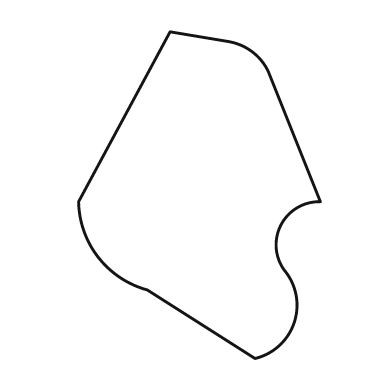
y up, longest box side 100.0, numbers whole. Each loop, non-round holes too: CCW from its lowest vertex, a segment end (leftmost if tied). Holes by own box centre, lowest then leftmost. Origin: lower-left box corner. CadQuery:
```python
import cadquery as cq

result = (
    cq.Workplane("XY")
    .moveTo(54.0, 0.0)
    .threePointArc((66.0, 11.0), (63.0, 27.0))
    .threePointArc((62.0, 41.0), (74.0, 48.0))
    .lineTo(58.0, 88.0)
    .threePointArc((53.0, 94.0), (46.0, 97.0))
    .lineTo(28.0, 100.0)
    .lineTo(0.0, 48.0)
    .threePointArc((6.0, 31.0), (21.0, 21.0))
    .close()
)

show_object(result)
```